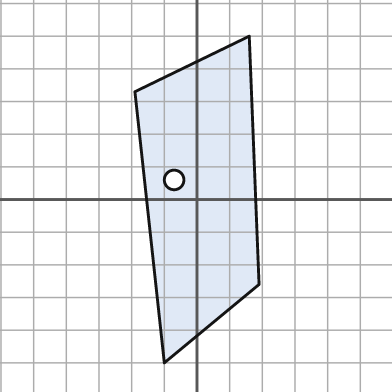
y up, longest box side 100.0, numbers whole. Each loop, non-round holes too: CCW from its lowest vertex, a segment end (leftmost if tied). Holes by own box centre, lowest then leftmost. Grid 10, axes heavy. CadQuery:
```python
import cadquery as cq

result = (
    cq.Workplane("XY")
    .moveTo(-10.0, -50.0)
    .lineTo(19.0, -26.0)
    .lineTo(16.0, 50.0)
    .lineTo(-19.0, 33.0)
    .close()
    .moveTo(-7.0, 6.0)
    .circle(3.0)
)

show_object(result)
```